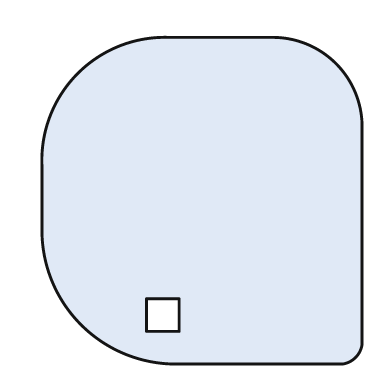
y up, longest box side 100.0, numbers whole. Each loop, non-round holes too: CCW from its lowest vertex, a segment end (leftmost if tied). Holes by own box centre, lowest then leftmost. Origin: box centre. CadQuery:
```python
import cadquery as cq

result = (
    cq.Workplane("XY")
    .moveTo(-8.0, -50.0)
    .lineTo(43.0, -50.0)
    .threePointArc((47.0, -48.0), (49.0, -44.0))
    .lineTo(49.0, 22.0)
    .threePointArc((41.0, 42.0), (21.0, 50.0))
    .lineTo(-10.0, 50.0)
    .threePointArc((-38.0, 39.0), (-49.0, 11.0))
    .lineTo(-49.0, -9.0)
    .threePointArc((-37.0, -38.0), (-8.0, -50.0))
    .close()
    .moveTo(-17.0, -40.0)
    .lineTo(-7.0, -40.0)
    .lineTo(-7.0, -30.0)
    .lineTo(-17.0, -30.0)
    .close()
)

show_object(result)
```